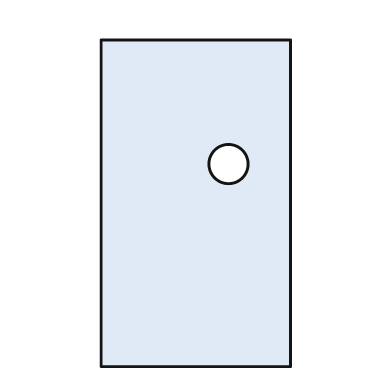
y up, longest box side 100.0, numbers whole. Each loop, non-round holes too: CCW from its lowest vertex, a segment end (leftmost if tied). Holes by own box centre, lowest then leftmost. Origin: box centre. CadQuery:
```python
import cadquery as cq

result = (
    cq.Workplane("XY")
    .moveTo(-29.0, -50.0)
    .lineTo(29.0, -50.0)
    .lineTo(29.0, 50.0)
    .lineTo(-29.0, 50.0)
    .close()
    .moveTo(10.0, 12.0)
    .circle(6.0)
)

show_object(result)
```